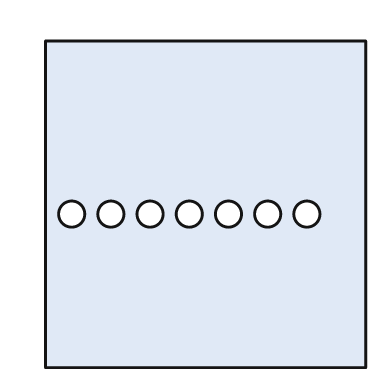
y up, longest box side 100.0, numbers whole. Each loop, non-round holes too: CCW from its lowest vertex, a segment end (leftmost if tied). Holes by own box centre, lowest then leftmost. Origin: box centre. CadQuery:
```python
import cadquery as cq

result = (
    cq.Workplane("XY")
    .moveTo(-49.0, -50.0)
    .lineTo(49.0, -50.0)
    .lineTo(49.0, 50.0)
    .lineTo(-49.0, 50.0)
    .close()
    .moveTo(-41.0, -3.0)
    .circle(4.0)
    .moveTo(-29.0, -3.0)
    .circle(4.0)
    .moveTo(-17.0, -3.0)
    .circle(4.0)
    .moveTo(-5.0, -3.0)
    .circle(4.0)
    .moveTo(7.0, -3.0)
    .circle(4.0)
    .moveTo(19.0, -3.0)
    .circle(4.0)
    .moveTo(31.0, -3.0)
    .circle(4.0)
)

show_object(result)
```